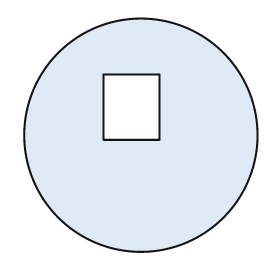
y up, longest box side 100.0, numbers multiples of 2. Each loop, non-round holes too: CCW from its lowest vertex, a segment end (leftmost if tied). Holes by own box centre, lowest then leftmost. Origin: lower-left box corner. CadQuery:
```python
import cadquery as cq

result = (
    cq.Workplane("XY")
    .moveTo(50.0, 50.0)
    .circle(50.0)
    .moveTo(34.0, 48.0)
    .lineTo(58.0, 48.0)
    .lineTo(58.0, 76.0)
    .lineTo(34.0, 76.0)
    .close()
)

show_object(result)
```